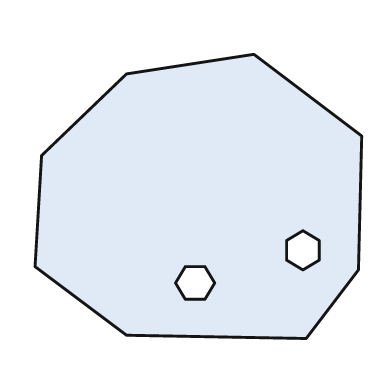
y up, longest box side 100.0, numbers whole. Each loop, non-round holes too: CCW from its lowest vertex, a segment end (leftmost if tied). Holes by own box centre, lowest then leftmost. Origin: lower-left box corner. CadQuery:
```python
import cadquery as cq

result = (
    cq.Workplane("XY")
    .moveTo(83.0, 0.0)
    .lineTo(99.0, 21.0)
    .lineTo(100.0, 62.0)
    .lineTo(67.0, 87.0)
    .lineTo(28.0, 81.0)
    .lineTo(2.0, 56.0)
    .lineTo(0.0, 22.0)
    .lineTo(28.0, 1.0)
    .close()
    .moveTo(46.0, 12.0)
    .lineTo(52.0, 12.0)
    .lineTo(55.0, 17.0)
    .lineTo(52.0, 22.0)
    .lineTo(46.0, 22.0)
    .lineTo(43.0, 17.0)
    .close()
    .moveTo(82.0, 21.0)
    .lineTo(87.0, 24.0)
    .lineTo(87.0, 30.0)
    .lineTo(82.0, 33.0)
    .lineTo(77.0, 30.0)
    .lineTo(77.0, 24.0)
    .close()
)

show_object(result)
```